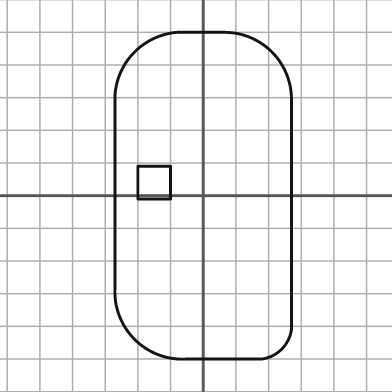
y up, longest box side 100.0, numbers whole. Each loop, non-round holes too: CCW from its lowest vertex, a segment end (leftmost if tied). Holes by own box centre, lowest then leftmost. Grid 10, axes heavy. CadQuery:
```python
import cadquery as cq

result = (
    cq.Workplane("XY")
    .moveTo(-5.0, -50.0)
    .lineTo(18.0, -50.0)
    .threePointArc((24.0, -47.0), (27.0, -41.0))
    .lineTo(27.0, 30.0)
    .threePointArc((21.0, 44.0), (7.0, 50.0))
    .lineTo(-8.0, 50.0)
    .threePointArc((-21.0, 44.0), (-27.0, 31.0))
    .lineTo(-27.0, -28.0)
    .threePointArc((-21.0, -44.0), (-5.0, -50.0))
    .close()
    .moveTo(-20.0, -1.0)
    .lineTo(-10.0, -1.0)
    .lineTo(-10.0, 9.0)
    .lineTo(-20.0, 9.0)
    .close()
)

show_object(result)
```